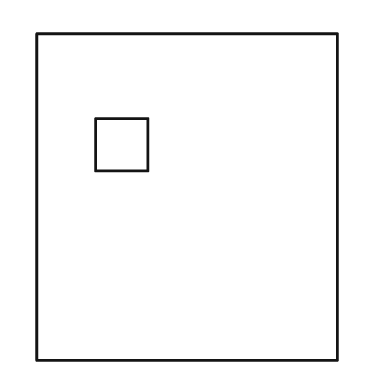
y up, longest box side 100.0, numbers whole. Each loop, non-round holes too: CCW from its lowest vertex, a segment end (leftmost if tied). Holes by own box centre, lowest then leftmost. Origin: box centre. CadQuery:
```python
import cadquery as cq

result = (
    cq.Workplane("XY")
    .moveTo(-46.0, -50.0)
    .lineTo(46.0, -50.0)
    .lineTo(46.0, 50.0)
    .lineTo(-46.0, 50.0)
    .close()
    .moveTo(-28.0, 8.0)
    .lineTo(-12.0, 8.0)
    .lineTo(-12.0, 24.0)
    .lineTo(-28.0, 24.0)
    .close()
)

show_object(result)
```